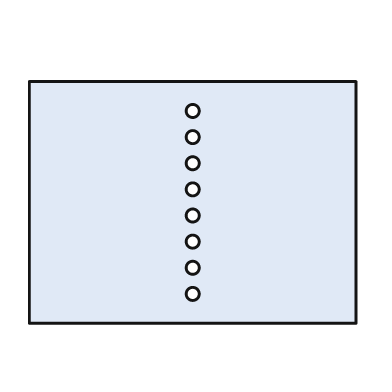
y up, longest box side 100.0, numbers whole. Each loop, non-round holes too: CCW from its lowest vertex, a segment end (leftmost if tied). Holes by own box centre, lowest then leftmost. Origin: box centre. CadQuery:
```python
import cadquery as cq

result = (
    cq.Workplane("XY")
    .moveTo(-50.0, -37.0)
    .lineTo(50.0, -37.0)
    .lineTo(50.0, 37.0)
    .lineTo(-50.0, 37.0)
    .close()
    .moveTo(0.0, -28.0)
    .circle(2.0)
    .moveTo(0.0, -20.0)
    .circle(2.0)
    .moveTo(0.0, -12.0)
    .circle(2.0)
    .moveTo(0.0, -4.0)
    .circle(2.0)
    .moveTo(0.0, 4.0)
    .circle(2.0)
    .moveTo(0.0, 12.0)
    .circle(2.0)
    .moveTo(0.0, 20.0)
    .circle(2.0)
    .moveTo(0.0, 28.0)
    .circle(2.0)
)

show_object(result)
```